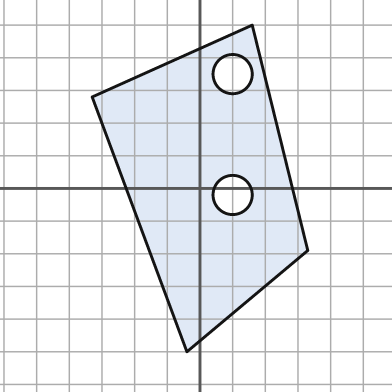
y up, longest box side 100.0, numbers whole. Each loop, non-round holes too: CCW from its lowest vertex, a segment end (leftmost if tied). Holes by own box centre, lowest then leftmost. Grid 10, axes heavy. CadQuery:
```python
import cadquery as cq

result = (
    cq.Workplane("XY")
    .moveTo(-4.0, -50.0)
    .lineTo(33.0, -19.0)
    .lineTo(16.0, 50.0)
    .lineTo(-33.0, 28.0)
    .close()
    .moveTo(10.0, -2.0)
    .circle(6.0)
    .moveTo(10.0, 35.0)
    .circle(6.0)
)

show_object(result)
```